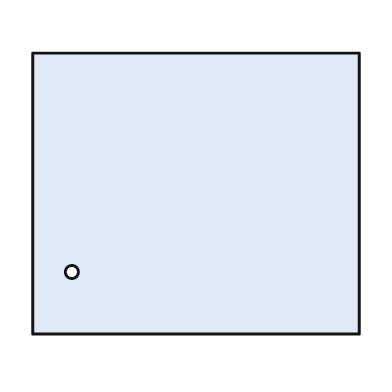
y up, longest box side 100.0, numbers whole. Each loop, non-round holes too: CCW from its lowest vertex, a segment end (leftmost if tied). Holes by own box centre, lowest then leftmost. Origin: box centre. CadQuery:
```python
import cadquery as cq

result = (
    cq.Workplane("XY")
    .moveTo(-50.0, -43.0)
    .lineTo(50.0, -43.0)
    .lineTo(50.0, 43.0)
    .lineTo(-50.0, 43.0)
    .close()
    .moveTo(-38.0, -24.0)
    .circle(2.0)
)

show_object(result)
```